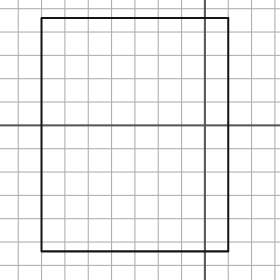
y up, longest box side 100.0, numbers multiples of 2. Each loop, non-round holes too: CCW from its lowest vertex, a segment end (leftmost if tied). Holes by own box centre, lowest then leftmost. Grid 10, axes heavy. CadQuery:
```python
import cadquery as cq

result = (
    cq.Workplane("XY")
    .moveTo(-70.0, -54.0)
    .lineTo(10.0, -54.0)
    .lineTo(10.0, 46.0)
    .lineTo(-70.0, 46.0)
    .close()
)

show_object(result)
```